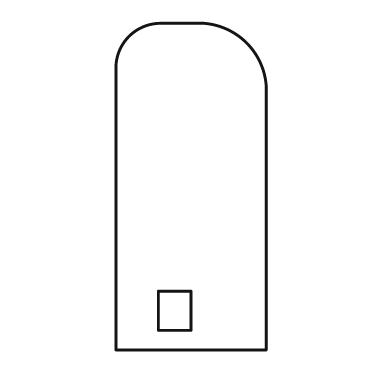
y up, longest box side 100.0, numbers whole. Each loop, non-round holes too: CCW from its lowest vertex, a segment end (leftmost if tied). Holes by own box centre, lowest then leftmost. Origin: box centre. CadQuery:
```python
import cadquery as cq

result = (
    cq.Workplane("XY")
    .moveTo(-23.0, -50.0)
    .lineTo(23.0, -50.0)
    .lineTo(23.0, 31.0)
    .threePointArc((17.0, 44.0), (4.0, 50.0))
    .lineTo(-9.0, 50.0)
    .threePointArc((-19.0, 46.0), (-23.0, 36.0))
    .close()
    .moveTo(-10.0, -44.0)
    .lineTo(0.0, -44.0)
    .lineTo(0.0, -32.0)
    .lineTo(-10.0, -32.0)
    .close()
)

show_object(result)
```